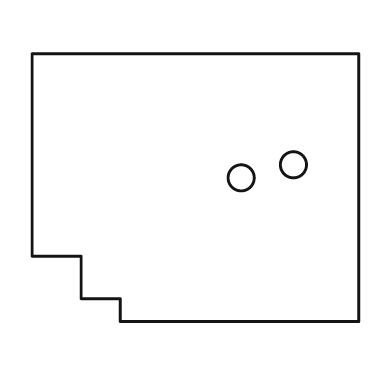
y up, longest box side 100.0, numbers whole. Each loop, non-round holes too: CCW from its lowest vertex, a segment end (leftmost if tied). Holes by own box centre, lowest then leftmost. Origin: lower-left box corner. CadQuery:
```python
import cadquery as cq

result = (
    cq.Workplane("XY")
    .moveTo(27.0, 0.0)
    .lineTo(100.0, 0.0)
    .lineTo(100.0, 82.0)
    .lineTo(0.0, 82.0)
    .lineTo(0.0, 20.0)
    .lineTo(15.0, 20.0)
    .lineTo(15.0, 7.0)
    .lineTo(27.0, 7.0)
    .close()
    .moveTo(64.0, 44.0)
    .circle(4.0)
    .moveTo(80.0, 48.0)
    .circle(4.0)
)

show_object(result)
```